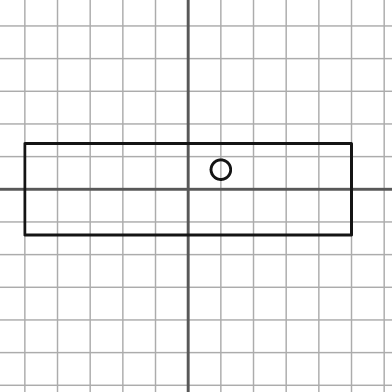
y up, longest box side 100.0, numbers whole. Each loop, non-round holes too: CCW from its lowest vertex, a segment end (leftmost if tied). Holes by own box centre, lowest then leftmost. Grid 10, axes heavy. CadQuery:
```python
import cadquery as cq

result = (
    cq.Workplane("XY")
    .moveTo(-50.0, -14.0)
    .lineTo(50.0, -14.0)
    .lineTo(50.0, 14.0)
    .lineTo(-50.0, 14.0)
    .close()
    .moveTo(10.0, 6.0)
    .circle(3.0)
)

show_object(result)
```